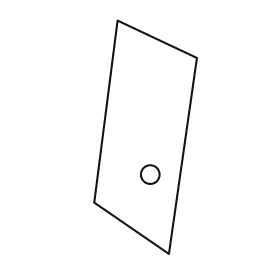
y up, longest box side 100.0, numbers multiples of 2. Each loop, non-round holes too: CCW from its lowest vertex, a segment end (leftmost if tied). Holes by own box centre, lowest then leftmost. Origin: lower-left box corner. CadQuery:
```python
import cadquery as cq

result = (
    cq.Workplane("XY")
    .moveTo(32.0, 0.0)
    .lineTo(44.0, 84.0)
    .lineTo(10.0, 100.0)
    .lineTo(0.0, 22.0)
    .close()
    .moveTo(24.0, 34.0)
    .circle(4.0)
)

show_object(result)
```